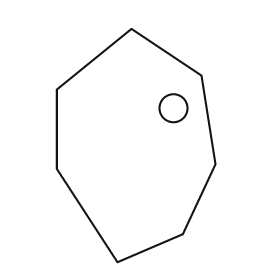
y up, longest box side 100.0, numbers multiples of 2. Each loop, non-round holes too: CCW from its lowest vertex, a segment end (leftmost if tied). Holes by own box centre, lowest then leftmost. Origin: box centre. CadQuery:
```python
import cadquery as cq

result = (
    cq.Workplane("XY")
    .moveTo(-8.0, -50.0)
    .lineTo(20.0, -38.0)
    .lineTo(34.0, -8.0)
    .lineTo(28.0, 30.0)
    .lineTo(-2.0, 50.0)
    .lineTo(-34.0, 24.0)
    .lineTo(-34.0, -10.0)
    .close()
    .moveTo(16.0, 16.0)
    .circle(6.0)
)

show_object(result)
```